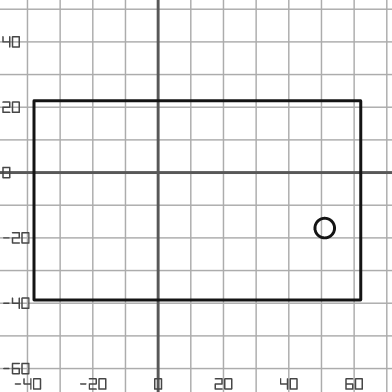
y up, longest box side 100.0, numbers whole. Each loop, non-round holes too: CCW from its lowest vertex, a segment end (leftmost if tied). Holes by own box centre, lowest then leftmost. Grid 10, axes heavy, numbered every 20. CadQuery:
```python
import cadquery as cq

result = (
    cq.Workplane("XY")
    .moveTo(-38.0, -39.0)
    .lineTo(62.0, -39.0)
    .lineTo(62.0, 22.0)
    .lineTo(-38.0, 22.0)
    .close()
    .moveTo(51.0, -17.0)
    .circle(3.0)
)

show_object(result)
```